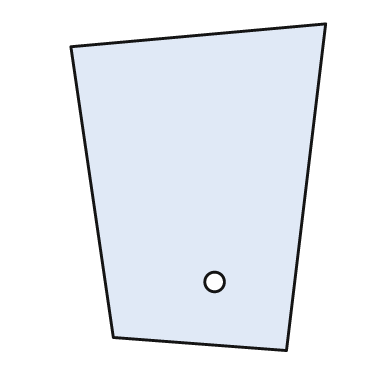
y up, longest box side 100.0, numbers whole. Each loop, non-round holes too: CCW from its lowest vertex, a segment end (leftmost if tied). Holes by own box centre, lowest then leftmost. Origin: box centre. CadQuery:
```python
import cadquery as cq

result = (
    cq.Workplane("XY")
    .moveTo(27.0, -50.0)
    .lineTo(39.0, 50.0)
    .lineTo(-39.0, 43.0)
    .lineTo(-26.0, -46.0)
    .close()
    .moveTo(5.0, -29.0)
    .circle(3.0)
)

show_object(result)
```